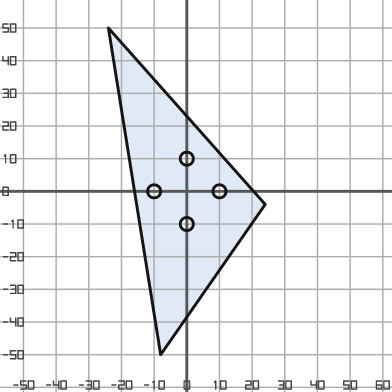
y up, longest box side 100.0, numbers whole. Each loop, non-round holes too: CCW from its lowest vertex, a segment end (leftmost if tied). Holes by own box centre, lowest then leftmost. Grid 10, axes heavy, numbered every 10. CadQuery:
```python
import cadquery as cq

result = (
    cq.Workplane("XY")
    .moveTo(-8.0, -50.0)
    .lineTo(24.0, -4.0)
    .lineTo(-24.0, 50.0)
    .close()
    .moveTo(0.0, -10.0)
    .circle(2.0)
    .moveTo(-10.0, 0.0)
    .circle(2.0)
    .moveTo(10.0, 0.0)
    .circle(2.0)
    .moveTo(0.0, 10.0)
    .circle(2.0)
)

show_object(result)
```